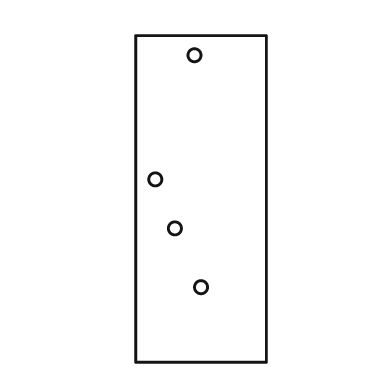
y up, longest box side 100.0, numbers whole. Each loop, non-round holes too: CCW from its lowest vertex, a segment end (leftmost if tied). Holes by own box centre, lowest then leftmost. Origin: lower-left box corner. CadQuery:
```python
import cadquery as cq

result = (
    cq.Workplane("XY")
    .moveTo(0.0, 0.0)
    .lineTo(40.0, 0.0)
    .lineTo(40.0, 100.0)
    .lineTo(0.0, 100.0)
    .close()
    .moveTo(20.0, 23.0)
    .circle(2.0)
    .moveTo(12.0, 41.0)
    .circle(2.0)
    .moveTo(6.0, 56.0)
    .circle(2.0)
    .moveTo(18.0, 94.0)
    .circle(2.0)
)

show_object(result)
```